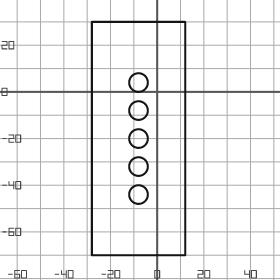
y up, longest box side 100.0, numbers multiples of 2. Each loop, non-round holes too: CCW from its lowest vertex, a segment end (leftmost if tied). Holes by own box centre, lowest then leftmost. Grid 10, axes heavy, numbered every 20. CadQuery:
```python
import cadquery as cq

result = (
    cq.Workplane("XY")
    .moveTo(-28.0, -70.0)
    .lineTo(12.0, -70.0)
    .lineTo(12.0, 30.0)
    .lineTo(-28.0, 30.0)
    .close()
    .moveTo(-8.0, -44.0)
    .circle(4.0)
    .moveTo(-8.0, -32.0)
    .circle(4.0)
    .moveTo(-8.0, -20.0)
    .circle(4.0)
    .moveTo(-8.0, -8.0)
    .circle(4.0)
    .moveTo(-8.0, 4.0)
    .circle(4.0)
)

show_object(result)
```